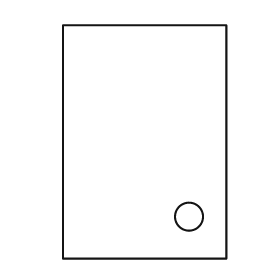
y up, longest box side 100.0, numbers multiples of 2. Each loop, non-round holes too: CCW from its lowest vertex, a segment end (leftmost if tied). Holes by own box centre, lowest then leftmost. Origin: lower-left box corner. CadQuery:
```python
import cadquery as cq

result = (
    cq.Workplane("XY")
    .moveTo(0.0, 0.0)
    .lineTo(70.0, 0.0)
    .lineTo(70.0, 100.0)
    .lineTo(0.0, 100.0)
    .close()
    .moveTo(54.0, 18.0)
    .circle(6.0)
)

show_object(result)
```